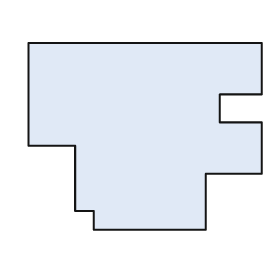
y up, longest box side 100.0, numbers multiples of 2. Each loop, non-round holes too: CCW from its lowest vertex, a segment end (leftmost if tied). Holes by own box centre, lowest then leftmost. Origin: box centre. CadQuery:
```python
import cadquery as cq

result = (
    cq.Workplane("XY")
    .moveTo(-22.0, -40.0)
    .lineTo(26.0, -40.0)
    .lineTo(26.0, -16.0)
    .lineTo(50.0, -16.0)
    .lineTo(50.0, 6.0)
    .lineTo(32.0, 6.0)
    .lineTo(32.0, 18.0)
    .lineTo(50.0, 18.0)
    .lineTo(50.0, 40.0)
    .lineTo(-50.0, 40.0)
    .lineTo(-50.0, -4.0)
    .lineTo(-30.0, -4.0)
    .lineTo(-30.0, -32.0)
    .lineTo(-22.0, -32.0)
    .close()
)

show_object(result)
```